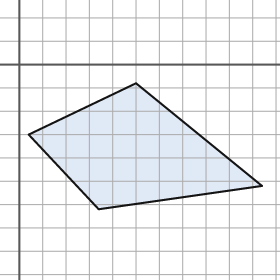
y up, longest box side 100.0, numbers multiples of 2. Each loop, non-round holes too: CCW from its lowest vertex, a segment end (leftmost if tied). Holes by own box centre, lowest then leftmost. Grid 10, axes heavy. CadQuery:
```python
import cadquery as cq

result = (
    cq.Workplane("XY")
    .moveTo(34.0, -62.0)
    .lineTo(104.0, -52.0)
    .lineTo(50.0, -8.0)
    .lineTo(4.0, -30.0)
    .close()
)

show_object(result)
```